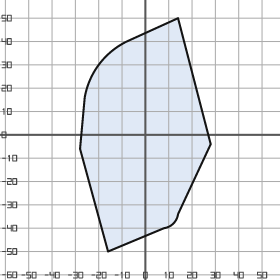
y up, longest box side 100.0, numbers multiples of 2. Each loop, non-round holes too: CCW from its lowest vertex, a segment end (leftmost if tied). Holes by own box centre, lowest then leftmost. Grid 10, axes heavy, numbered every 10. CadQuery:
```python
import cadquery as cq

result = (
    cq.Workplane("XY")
    .moveTo(-16.0, -50.0)
    .lineTo(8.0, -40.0)
    .threePointArc((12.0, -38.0), (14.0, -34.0))
    .lineTo(28.0, -4.0)
    .lineTo(14.0, 50.0)
    .lineTo(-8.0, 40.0)
    .threePointArc((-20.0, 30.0), (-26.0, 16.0))
    .lineTo(-28.0, -6.0)
    .close()
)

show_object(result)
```